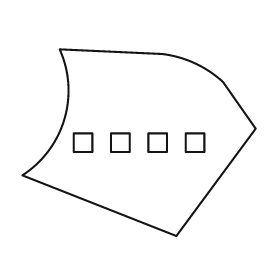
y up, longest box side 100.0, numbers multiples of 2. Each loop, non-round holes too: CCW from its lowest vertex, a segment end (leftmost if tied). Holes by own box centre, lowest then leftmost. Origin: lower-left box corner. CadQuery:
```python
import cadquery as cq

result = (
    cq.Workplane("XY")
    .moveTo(66.0, 0.0)
    .lineTo(100.0, 46.0)
    .lineTo(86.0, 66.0)
    .threePointArc((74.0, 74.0), (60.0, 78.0))
    .lineTo(16.0, 80.0)
    .threePointArc((18.0, 50.0), (0.0, 26.0))
    .close()
    .moveTo(22.0, 36.0)
    .lineTo(30.0, 36.0)
    .lineTo(30.0, 44.0)
    .lineTo(22.0, 44.0)
    .close()
    .moveTo(38.0, 36.0)
    .lineTo(46.0, 36.0)
    .lineTo(46.0, 44.0)
    .lineTo(38.0, 44.0)
    .close()
    .moveTo(54.0, 36.0)
    .lineTo(62.0, 36.0)
    .lineTo(62.0, 44.0)
    .lineTo(54.0, 44.0)
    .close()
    .moveTo(70.0, 36.0)
    .lineTo(78.0, 36.0)
    .lineTo(78.0, 44.0)
    .lineTo(70.0, 44.0)
    .close()
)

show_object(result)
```